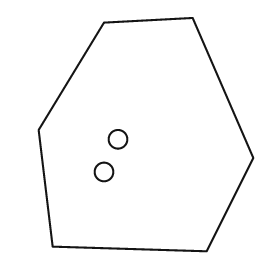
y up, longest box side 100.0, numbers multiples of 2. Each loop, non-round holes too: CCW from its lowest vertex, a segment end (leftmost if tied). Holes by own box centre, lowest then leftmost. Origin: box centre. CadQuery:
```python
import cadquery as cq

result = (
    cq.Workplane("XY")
    .moveTo(26.0, -50.0)
    .lineTo(46.0, -10.0)
    .lineTo(20.0, 50.0)
    .lineTo(-18.0, 48.0)
    .lineTo(-46.0, 2.0)
    .lineTo(-40.0, -48.0)
    .close()
    .moveTo(-18.0, -16.0)
    .circle(4.0)
    .moveTo(-12.0, -2.0)
    .circle(4.0)
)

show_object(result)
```